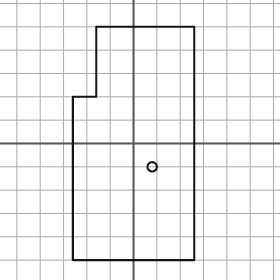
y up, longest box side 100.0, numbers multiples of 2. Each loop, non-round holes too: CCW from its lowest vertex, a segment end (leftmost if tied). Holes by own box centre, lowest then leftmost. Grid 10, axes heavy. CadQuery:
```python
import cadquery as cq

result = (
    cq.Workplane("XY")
    .moveTo(-26.0, -50.0)
    .lineTo(26.0, -50.0)
    .lineTo(26.0, 50.0)
    .lineTo(-16.0, 50.0)
    .lineTo(-16.0, 20.0)
    .lineTo(-26.0, 20.0)
    .close()
    .moveTo(8.0, -10.0)
    .circle(2.0)
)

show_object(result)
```